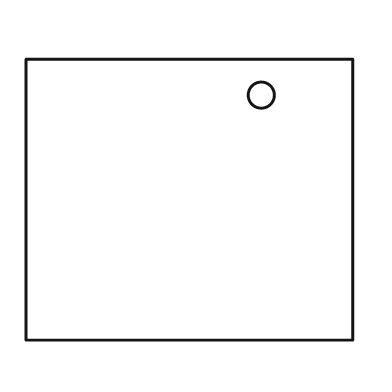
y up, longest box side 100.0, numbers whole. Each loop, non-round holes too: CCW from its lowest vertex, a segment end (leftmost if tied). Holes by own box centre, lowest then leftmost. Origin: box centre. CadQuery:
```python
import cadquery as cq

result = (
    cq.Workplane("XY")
    .moveTo(-50.0, -43.0)
    .lineTo(50.0, -43.0)
    .lineTo(50.0, 43.0)
    .lineTo(-50.0, 43.0)
    .close()
    .moveTo(22.0, 32.0)
    .circle(4.0)
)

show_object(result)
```